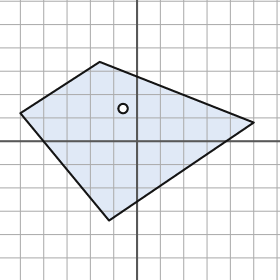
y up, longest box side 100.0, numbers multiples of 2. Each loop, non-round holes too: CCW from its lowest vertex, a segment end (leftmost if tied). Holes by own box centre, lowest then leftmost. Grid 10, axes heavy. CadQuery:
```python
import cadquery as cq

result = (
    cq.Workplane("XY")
    .moveTo(-12.0, -34.0)
    .lineTo(50.0, 8.0)
    .lineTo(-16.0, 34.0)
    .lineTo(-50.0, 12.0)
    .close()
    .moveTo(-6.0, 14.0)
    .circle(2.0)
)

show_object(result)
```